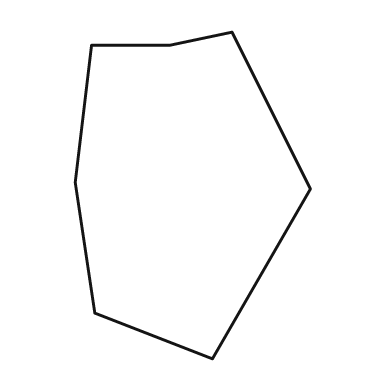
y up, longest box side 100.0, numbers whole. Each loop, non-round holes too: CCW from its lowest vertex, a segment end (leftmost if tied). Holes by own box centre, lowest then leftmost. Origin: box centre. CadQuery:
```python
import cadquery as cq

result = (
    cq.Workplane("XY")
    .moveTo(6.0, -50.0)
    .lineTo(36.0, 2.0)
    .lineTo(12.0, 50.0)
    .lineTo(-7.0, 46.0)
    .lineTo(-31.0, 46.0)
    .lineTo(-36.0, 4.0)
    .lineTo(-30.0, -36.0)
    .close()
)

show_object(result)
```